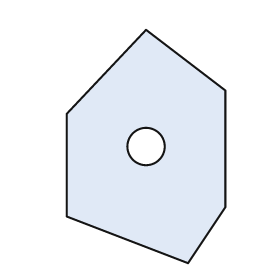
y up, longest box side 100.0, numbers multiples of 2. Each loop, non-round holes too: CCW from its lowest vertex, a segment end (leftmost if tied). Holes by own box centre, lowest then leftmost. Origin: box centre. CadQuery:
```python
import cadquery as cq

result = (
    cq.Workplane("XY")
    .moveTo(18.0, -50.0)
    .lineTo(34.0, -26.0)
    .lineTo(34.0, 24.0)
    .lineTo(0.0, 50.0)
    .lineTo(-34.0, 14.0)
    .lineTo(-34.0, -30.0)
    .close()
    .moveTo(0.0, 0.0)
    .circle(8.0)
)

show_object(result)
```